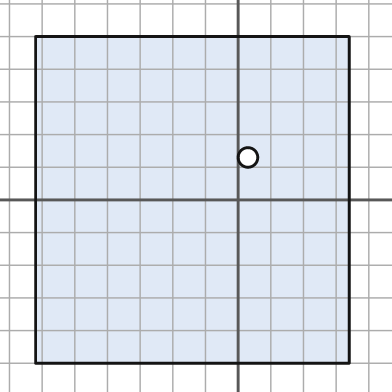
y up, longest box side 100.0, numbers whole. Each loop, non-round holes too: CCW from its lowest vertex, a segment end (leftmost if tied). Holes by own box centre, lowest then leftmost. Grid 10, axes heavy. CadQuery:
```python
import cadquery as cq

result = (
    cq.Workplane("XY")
    .moveTo(-62.0, -50.0)
    .lineTo(34.0, -50.0)
    .lineTo(34.0, 50.0)
    .lineTo(-62.0, 50.0)
    .close()
    .moveTo(3.0, 13.0)
    .circle(3.0)
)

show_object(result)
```